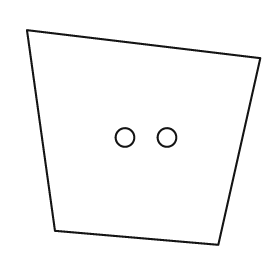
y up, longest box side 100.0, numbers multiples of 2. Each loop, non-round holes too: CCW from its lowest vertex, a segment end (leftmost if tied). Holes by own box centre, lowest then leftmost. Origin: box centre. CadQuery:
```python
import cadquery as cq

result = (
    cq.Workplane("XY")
    .moveTo(32.0, -46.0)
    .lineTo(50.0, 34.0)
    .lineTo(-50.0, 46.0)
    .lineTo(-38.0, -40.0)
    .close()
    .moveTo(-8.0, 0.0)
    .circle(4.0)
    .moveTo(10.0, 0.0)
    .circle(4.0)
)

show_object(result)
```